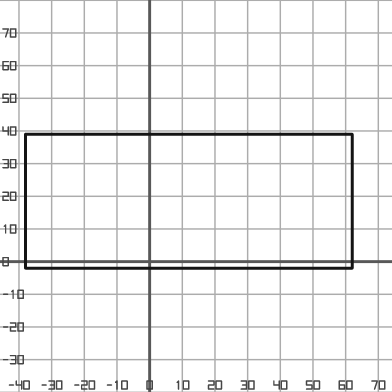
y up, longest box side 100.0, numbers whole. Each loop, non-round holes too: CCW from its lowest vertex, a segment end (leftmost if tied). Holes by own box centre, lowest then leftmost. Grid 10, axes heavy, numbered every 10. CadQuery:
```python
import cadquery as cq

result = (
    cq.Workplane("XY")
    .moveTo(-38.0, -2.0)
    .lineTo(62.0, -2.0)
    .lineTo(62.0, 39.0)
    .lineTo(-38.0, 39.0)
    .close()
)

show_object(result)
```